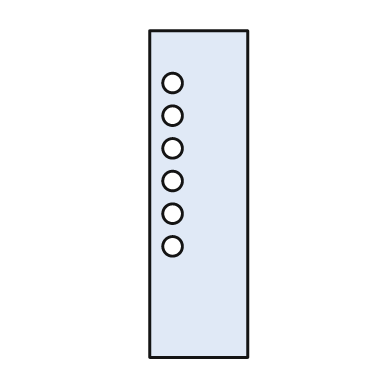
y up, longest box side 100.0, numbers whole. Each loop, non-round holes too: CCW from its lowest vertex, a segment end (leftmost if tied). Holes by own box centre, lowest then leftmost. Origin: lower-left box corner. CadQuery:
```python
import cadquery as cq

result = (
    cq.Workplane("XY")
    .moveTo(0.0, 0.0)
    .lineTo(30.0, 0.0)
    .lineTo(30.0, 100.0)
    .lineTo(0.0, 100.0)
    .close()
    .moveTo(7.0, 34.0)
    .circle(3.0)
    .moveTo(7.0, 44.0)
    .circle(3.0)
    .moveTo(7.0, 54.0)
    .circle(3.0)
    .moveTo(7.0, 64.0)
    .circle(3.0)
    .moveTo(7.0, 74.0)
    .circle(3.0)
    .moveTo(7.0, 84.0)
    .circle(3.0)
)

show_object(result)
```